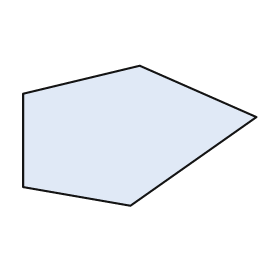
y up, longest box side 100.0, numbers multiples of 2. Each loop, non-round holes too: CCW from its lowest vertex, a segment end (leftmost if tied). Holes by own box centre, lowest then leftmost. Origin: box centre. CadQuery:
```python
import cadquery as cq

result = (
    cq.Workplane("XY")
    .moveTo(-4.0, -30.0)
    .lineTo(50.0, 8.0)
    .lineTo(0.0, 30.0)
    .lineTo(-50.0, 18.0)
    .lineTo(-50.0, -22.0)
    .close()
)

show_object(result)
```